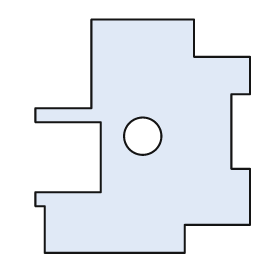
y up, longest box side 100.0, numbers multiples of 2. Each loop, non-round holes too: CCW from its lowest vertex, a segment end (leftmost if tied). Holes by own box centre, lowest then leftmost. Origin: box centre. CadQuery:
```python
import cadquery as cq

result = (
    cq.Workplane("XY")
    .moveTo(-42.0, -50.0)
    .lineTo(18.0, -50.0)
    .lineTo(18.0, -38.0)
    .lineTo(46.0, -38.0)
    .lineTo(46.0, -14.0)
    .lineTo(38.0, -14.0)
    .lineTo(38.0, 18.0)
    .lineTo(46.0, 18.0)
    .lineTo(46.0, 34.0)
    .lineTo(22.0, 34.0)
    .lineTo(22.0, 50.0)
    .lineTo(-22.0, 50.0)
    .lineTo(-22.0, 12.0)
    .lineTo(-46.0, 12.0)
    .lineTo(-46.0, 6.0)
    .lineTo(-18.0, 6.0)
    .lineTo(-18.0, -24.0)
    .lineTo(-46.0, -24.0)
    .lineTo(-46.0, -30.0)
    .lineTo(-42.0, -30.0)
    .close()
    .moveTo(0.0, 0.0)
    .circle(8.0)
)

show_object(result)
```